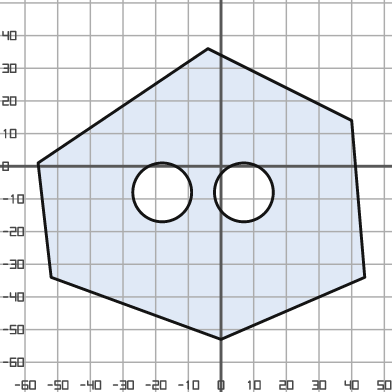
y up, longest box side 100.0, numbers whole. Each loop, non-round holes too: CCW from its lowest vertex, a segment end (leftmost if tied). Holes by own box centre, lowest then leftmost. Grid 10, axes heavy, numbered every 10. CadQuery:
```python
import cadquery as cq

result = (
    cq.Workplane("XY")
    .moveTo(0.0, -53.0)
    .lineTo(44.0, -34.0)
    .lineTo(40.0, 14.0)
    .lineTo(-4.0, 36.0)
    .lineTo(-56.0, 1.0)
    .lineTo(-52.0, -34.0)
    .close()
    .moveTo(-18.0, -8.0)
    .circle(9.0)
    .moveTo(7.0, -8.0)
    .circle(9.0)
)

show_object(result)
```